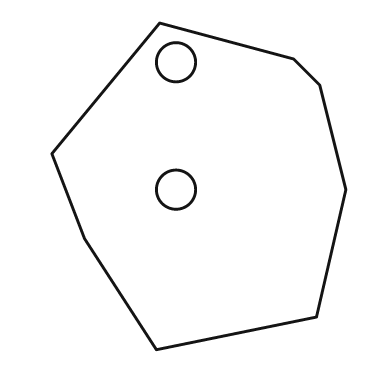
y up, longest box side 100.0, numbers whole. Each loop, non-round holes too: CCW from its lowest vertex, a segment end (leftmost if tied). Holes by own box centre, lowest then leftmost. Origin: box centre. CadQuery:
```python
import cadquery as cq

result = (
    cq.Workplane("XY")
    .moveTo(-13.0, -50.0)
    .lineTo(36.0, -40.0)
    .lineTo(45.0, -1.0)
    .lineTo(37.0, 31.0)
    .lineTo(29.0, 39.0)
    .lineTo(-12.0, 50.0)
    .lineTo(-45.0, 10.0)
    .lineTo(-35.0, -16.0)
    .close()
    .moveTo(-7.0, -1.0)
    .circle(6.0)
    .moveTo(-7.0, 38.0)
    .circle(6.0)
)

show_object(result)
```